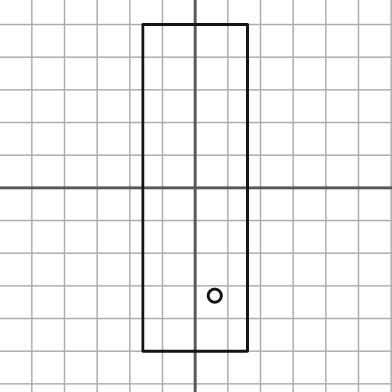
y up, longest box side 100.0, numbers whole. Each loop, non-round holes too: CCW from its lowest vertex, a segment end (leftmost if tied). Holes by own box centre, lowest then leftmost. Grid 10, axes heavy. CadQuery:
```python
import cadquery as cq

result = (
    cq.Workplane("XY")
    .moveTo(-16.0, -50.0)
    .lineTo(16.0, -50.0)
    .lineTo(16.0, 50.0)
    .lineTo(-16.0, 50.0)
    .close()
    .moveTo(6.0, -33.0)
    .circle(2.0)
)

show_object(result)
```